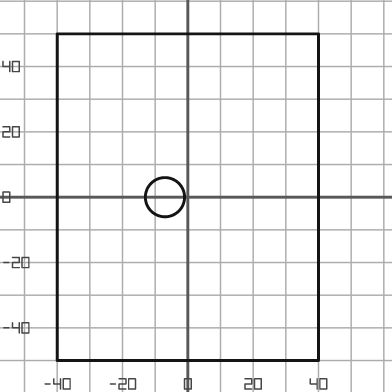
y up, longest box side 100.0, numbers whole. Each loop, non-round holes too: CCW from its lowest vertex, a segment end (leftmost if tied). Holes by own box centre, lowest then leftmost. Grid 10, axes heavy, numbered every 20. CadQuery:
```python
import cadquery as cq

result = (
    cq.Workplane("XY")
    .moveTo(-40.0, -50.0)
    .lineTo(40.0, -50.0)
    .lineTo(40.0, 50.0)
    .lineTo(-40.0, 50.0)
    .close()
    .moveTo(-7.0, 0.0)
    .circle(6.0)
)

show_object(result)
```